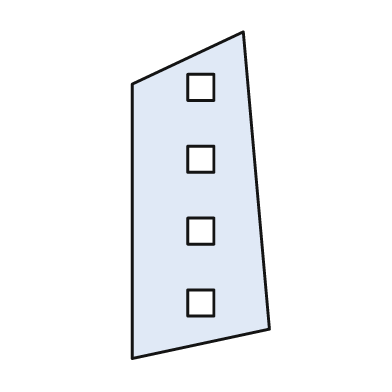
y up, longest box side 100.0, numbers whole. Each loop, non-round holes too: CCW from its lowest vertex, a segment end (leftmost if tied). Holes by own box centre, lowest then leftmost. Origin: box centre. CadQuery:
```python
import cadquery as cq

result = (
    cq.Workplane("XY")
    .moveTo(-21.0, -50.0)
    .lineTo(21.0, -41.0)
    .lineTo(13.0, 50.0)
    .lineTo(-21.0, 34.0)
    .close()
    .moveTo(-4.0, -37.0)
    .lineTo(4.0, -37.0)
    .lineTo(4.0, -29.0)
    .lineTo(-4.0, -29.0)
    .close()
    .moveTo(-4.0, -15.0)
    .lineTo(4.0, -15.0)
    .lineTo(4.0, -7.0)
    .lineTo(-4.0, -7.0)
    .close()
    .moveTo(-4.0, 7.0)
    .lineTo(4.0, 7.0)
    .lineTo(4.0, 15.0)
    .lineTo(-4.0, 15.0)
    .close()
    .moveTo(-4.0, 29.0)
    .lineTo(4.0, 29.0)
    .lineTo(4.0, 37.0)
    .lineTo(-4.0, 37.0)
    .close()
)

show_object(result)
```